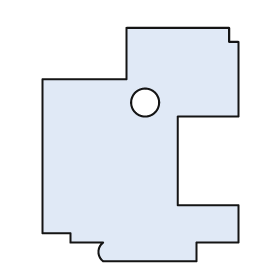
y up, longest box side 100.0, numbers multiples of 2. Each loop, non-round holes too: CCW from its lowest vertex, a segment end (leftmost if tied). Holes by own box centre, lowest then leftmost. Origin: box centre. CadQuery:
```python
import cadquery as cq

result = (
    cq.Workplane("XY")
    .moveTo(-16.0, -50.0)
    .lineTo(24.0, -50.0)
    .lineTo(24.0, -42.0)
    .lineTo(42.0, -42.0)
    .lineTo(42.0, -26.0)
    .lineTo(16.0, -26.0)
    .lineTo(16.0, 12.0)
    .lineTo(42.0, 12.0)
    .lineTo(42.0, 44.0)
    .lineTo(38.0, 44.0)
    .lineTo(38.0, 50.0)
    .lineTo(-6.0, 50.0)
    .lineTo(-6.0, 28.0)
    .lineTo(-42.0, 28.0)
    .lineTo(-42.0, -38.0)
    .lineTo(-30.0, -38.0)
    .lineTo(-30.0, -42.0)
    .lineTo(-16.0, -42.0)
    .threePointArc((-18.0, -46.0), (-16.0, -50.0))
    .close()
    .moveTo(2.0, 18.0)
    .circle(6.0)
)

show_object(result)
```